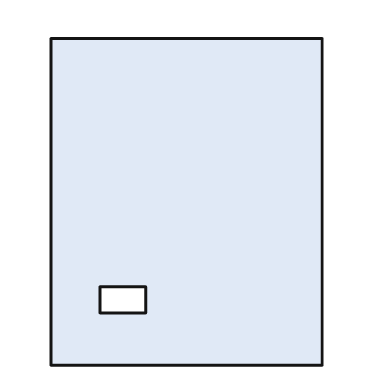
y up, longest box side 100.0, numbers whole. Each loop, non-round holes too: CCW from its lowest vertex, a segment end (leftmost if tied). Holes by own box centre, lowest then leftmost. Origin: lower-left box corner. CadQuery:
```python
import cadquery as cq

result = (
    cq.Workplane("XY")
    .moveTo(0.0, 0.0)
    .lineTo(83.0, 0.0)
    .lineTo(83.0, 100.0)
    .lineTo(0.0, 100.0)
    .close()
    .moveTo(15.0, 16.0)
    .lineTo(29.0, 16.0)
    .lineTo(29.0, 24.0)
    .lineTo(15.0, 24.0)
    .close()
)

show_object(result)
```